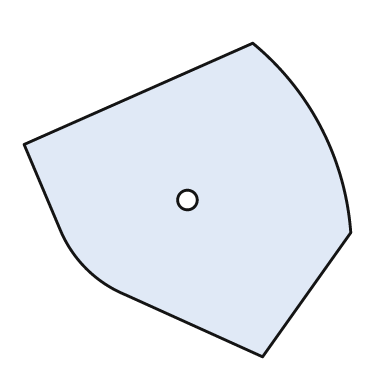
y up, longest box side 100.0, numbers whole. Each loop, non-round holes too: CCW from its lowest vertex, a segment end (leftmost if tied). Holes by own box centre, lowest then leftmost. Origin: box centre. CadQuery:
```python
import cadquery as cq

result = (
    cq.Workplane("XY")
    .moveTo(23.0, -48.0)
    .lineTo(50.0, -10.0)
    .threePointArc((41.0, 22.0), (20.0, 48.0))
    .lineTo(-50.0, 17.0)
    .lineTo(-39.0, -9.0)
    .threePointArc((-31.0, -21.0), (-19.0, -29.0))
    .close()
    .moveTo(0.0, 0.0)
    .circle(3.0)
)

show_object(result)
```